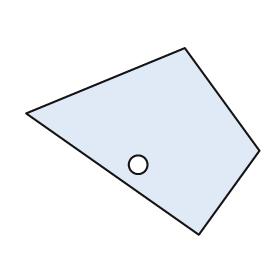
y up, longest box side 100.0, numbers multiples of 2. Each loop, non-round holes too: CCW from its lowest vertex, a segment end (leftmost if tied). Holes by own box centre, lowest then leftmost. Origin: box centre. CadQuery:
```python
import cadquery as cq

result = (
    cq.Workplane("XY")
    .moveTo(24.0, -40.0)
    .lineTo(50.0, -4.0)
    .lineTo(18.0, 40.0)
    .lineTo(-50.0, 12.0)
    .close()
    .moveTo(-2.0, -10.0)
    .circle(4.0)
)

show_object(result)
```